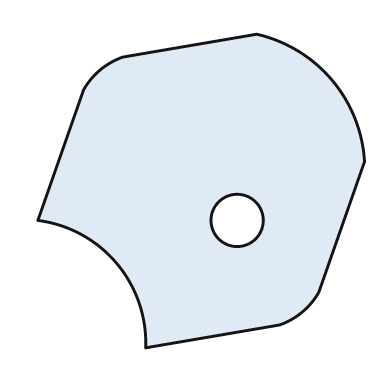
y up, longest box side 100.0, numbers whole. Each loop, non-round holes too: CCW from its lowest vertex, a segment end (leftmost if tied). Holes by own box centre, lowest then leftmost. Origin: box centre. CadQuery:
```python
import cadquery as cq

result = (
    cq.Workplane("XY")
    .moveTo(-17.0, -48.0)
    .lineTo(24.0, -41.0)
    .threePointArc((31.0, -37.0), (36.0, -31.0))
    .lineTo(50.0, 9.0)
    .threePointArc((40.0, 34.0), (17.0, 48.0))
    .lineTo(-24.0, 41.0)
    .threePointArc((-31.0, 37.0), (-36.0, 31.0))
    .lineTo(-50.0, -9.0)
    .threePointArc((-26.0, -22.0), (-17.0, -48.0))
    .close()
    .moveTo(11.0, -9.0)
    .circle(8.0)
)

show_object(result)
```